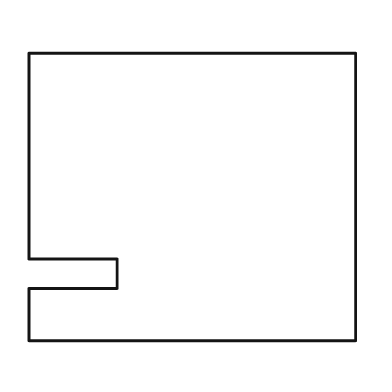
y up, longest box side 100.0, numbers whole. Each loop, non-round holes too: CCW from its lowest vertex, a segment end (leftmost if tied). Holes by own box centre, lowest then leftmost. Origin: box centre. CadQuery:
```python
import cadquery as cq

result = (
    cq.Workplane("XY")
    .moveTo(-50.0, -44.0)
    .lineTo(50.0, -44.0)
    .lineTo(50.0, 44.0)
    .lineTo(-50.0, 44.0)
    .lineTo(-50.0, -19.0)
    .lineTo(-23.0, -19.0)
    .lineTo(-23.0, -28.0)
    .lineTo(-50.0, -28.0)
    .close()
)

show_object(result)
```